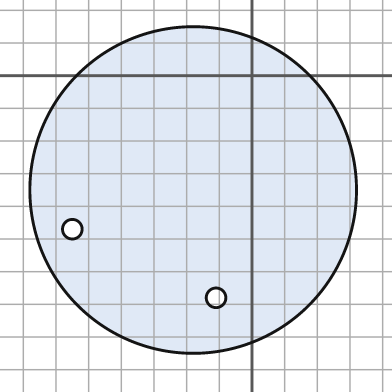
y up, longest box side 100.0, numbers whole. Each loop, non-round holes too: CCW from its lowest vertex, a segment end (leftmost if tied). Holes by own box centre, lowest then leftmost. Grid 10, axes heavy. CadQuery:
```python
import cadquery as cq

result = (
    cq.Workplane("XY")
    .moveTo(-18.0, -35.0)
    .circle(50.0)
    .moveTo(-11.0, -68.0)
    .circle(3.0)
    .moveTo(-55.0, -47.0)
    .circle(3.0)
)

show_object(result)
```